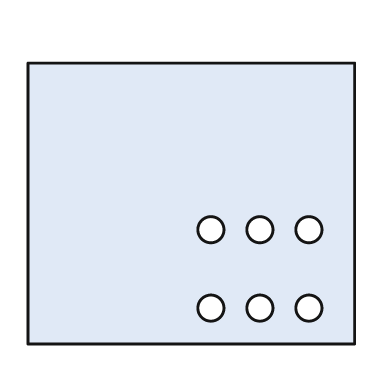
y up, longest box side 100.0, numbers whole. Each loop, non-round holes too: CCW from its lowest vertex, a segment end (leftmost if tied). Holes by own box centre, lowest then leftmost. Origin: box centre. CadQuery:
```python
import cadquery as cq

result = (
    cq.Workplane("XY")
    .moveTo(-50.0, -43.0)
    .lineTo(50.0, -43.0)
    .lineTo(50.0, 43.0)
    .lineTo(-50.0, 43.0)
    .close()
    .moveTo(6.0, -32.0)
    .circle(4.0)
    .moveTo(21.0, -32.0)
    .circle(4.0)
    .moveTo(36.0, -32.0)
    .circle(4.0)
    .moveTo(6.0, -8.0)
    .circle(4.0)
    .moveTo(21.0, -8.0)
    .circle(4.0)
    .moveTo(36.0, -8.0)
    .circle(4.0)
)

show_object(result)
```